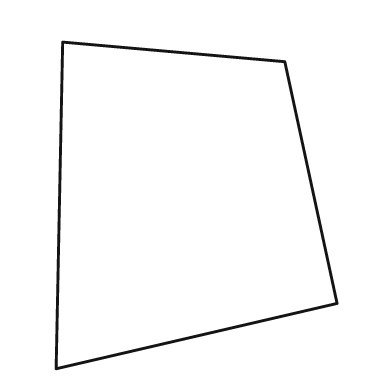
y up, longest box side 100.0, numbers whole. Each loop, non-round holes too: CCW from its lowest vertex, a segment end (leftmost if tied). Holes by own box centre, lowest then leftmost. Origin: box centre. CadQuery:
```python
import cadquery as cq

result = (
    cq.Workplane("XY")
    .moveTo(-43.0, -50.0)
    .lineTo(43.0, -30.0)
    .lineTo(27.0, 44.0)
    .lineTo(-41.0, 50.0)
    .close()
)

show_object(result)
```